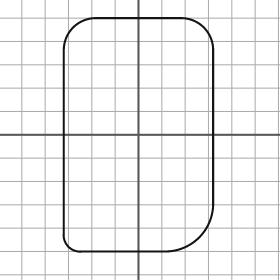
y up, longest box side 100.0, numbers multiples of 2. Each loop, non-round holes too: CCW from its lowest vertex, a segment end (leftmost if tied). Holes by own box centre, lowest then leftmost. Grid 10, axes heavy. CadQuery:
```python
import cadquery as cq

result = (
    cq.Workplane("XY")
    .moveTo(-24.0, -50.0)
    .lineTo(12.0, -50.0)
    .threePointArc((26.0, -44.0), (32.0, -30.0))
    .lineTo(32.0, 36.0)
    .threePointArc((28.0, 46.0), (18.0, 50.0))
    .lineTo(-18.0, 50.0)
    .threePointArc((-28.0, 46.0), (-32.0, 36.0))
    .lineTo(-32.0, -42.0)
    .threePointArc((-30.0, -48.0), (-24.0, -50.0))
    .close()
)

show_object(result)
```